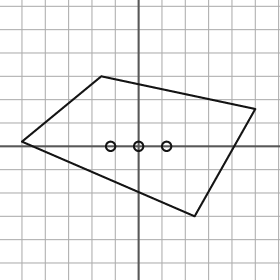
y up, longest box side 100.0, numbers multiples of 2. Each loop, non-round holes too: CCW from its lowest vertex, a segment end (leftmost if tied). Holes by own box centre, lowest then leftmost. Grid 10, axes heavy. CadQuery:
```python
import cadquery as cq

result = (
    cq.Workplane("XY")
    .moveTo(24.0, -30.0)
    .lineTo(50.0, 16.0)
    .lineTo(-16.0, 30.0)
    .lineTo(-50.0, 2.0)
    .close()
    .moveTo(-12.0, 0.0)
    .circle(2.0)
    .moveTo(0.0, 0.0)
    .circle(2.0)
    .moveTo(12.0, 0.0)
    .circle(2.0)
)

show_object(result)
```